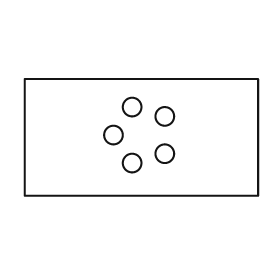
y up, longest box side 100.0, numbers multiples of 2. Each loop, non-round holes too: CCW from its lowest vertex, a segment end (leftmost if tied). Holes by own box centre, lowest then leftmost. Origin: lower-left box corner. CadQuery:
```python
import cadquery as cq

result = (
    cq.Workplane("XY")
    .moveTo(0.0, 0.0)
    .lineTo(100.0, 0.0)
    .lineTo(100.0, 50.0)
    .lineTo(0.0, 50.0)
    .close()
    .moveTo(46.0, 14.0)
    .circle(4.0)
    .moveTo(60.0, 18.0)
    .circle(4.0)
    .moveTo(38.0, 26.0)
    .circle(4.0)
    .moveTo(60.0, 34.0)
    .circle(4.0)
    .moveTo(46.0, 38.0)
    .circle(4.0)
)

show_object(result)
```